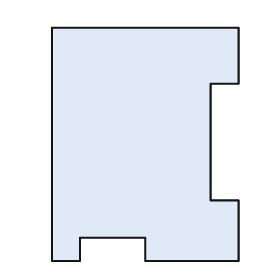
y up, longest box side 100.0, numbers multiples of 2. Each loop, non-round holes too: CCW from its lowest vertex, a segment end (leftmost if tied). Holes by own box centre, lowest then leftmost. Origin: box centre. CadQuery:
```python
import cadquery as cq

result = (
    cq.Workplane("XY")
    .moveTo(-40.0, -50.0)
    .lineTo(-28.0, -50.0)
    .lineTo(-28.0, -40.0)
    .lineTo(0.0, -40.0)
    .lineTo(0.0, -50.0)
    .lineTo(40.0, -50.0)
    .lineTo(40.0, -24.0)
    .lineTo(28.0, -24.0)
    .lineTo(28.0, 26.0)
    .lineTo(40.0, 26.0)
    .lineTo(40.0, 50.0)
    .lineTo(-40.0, 50.0)
    .close()
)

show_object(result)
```